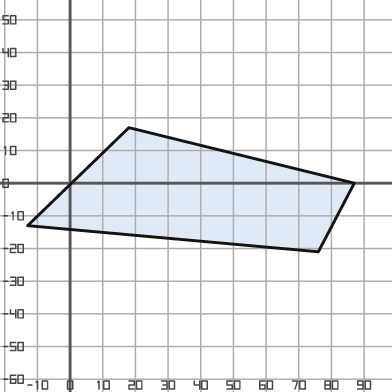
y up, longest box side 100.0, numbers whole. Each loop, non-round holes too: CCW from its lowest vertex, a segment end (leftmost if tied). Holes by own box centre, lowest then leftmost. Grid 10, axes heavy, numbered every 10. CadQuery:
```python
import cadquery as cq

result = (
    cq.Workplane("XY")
    .moveTo(76.0, -21.0)
    .lineTo(87.0, 0.0)
    .lineTo(18.0, 17.0)
    .lineTo(-13.0, -13.0)
    .close()
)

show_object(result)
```